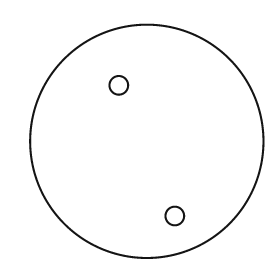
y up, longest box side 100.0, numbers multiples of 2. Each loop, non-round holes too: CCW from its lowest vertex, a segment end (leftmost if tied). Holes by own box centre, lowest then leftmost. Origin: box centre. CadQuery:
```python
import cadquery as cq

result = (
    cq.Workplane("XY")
    .moveTo(0.0, 0.0)
    .circle(50.0)
    .moveTo(12.0, -32.0)
    .circle(4.0)
    .moveTo(-12.0, 24.0)
    .circle(4.0)
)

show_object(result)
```